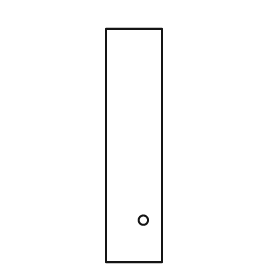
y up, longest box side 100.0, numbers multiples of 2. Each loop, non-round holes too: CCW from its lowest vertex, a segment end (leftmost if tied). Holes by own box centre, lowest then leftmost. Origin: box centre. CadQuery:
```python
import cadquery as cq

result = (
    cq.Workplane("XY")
    .moveTo(-12.0, -50.0)
    .lineTo(12.0, -50.0)
    .lineTo(12.0, 50.0)
    .lineTo(-12.0, 50.0)
    .close()
    .moveTo(4.0, -32.0)
    .circle(2.0)
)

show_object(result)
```